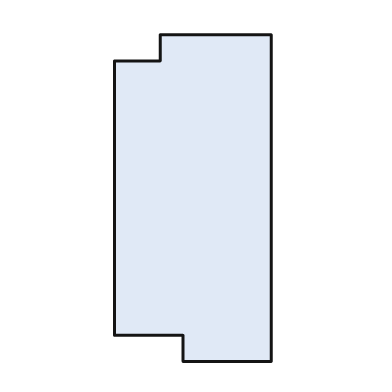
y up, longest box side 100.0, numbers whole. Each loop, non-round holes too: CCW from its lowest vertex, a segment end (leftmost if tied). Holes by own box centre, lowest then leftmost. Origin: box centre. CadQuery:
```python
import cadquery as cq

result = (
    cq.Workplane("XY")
    .moveTo(-3.0, -50.0)
    .lineTo(24.0, -50.0)
    .lineTo(24.0, 50.0)
    .lineTo(-10.0, 50.0)
    .lineTo(-10.0, 42.0)
    .lineTo(-24.0, 42.0)
    .lineTo(-24.0, -42.0)
    .lineTo(-3.0, -42.0)
    .close()
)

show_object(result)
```